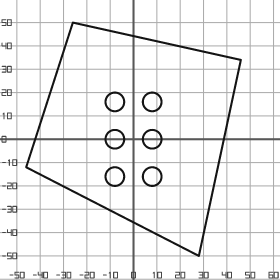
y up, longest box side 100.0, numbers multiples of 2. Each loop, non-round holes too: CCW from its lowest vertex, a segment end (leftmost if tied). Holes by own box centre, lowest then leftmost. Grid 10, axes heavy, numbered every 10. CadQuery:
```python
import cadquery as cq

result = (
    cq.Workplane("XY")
    .moveTo(28.0, -50.0)
    .lineTo(46.0, 34.0)
    .lineTo(-26.0, 50.0)
    .lineTo(-46.0, -12.0)
    .close()
    .moveTo(-8.0, -16.0)
    .circle(4.0)
    .moveTo(8.0, -16.0)
    .circle(4.0)
    .moveTo(-8.0, 0.0)
    .circle(4.0)
    .moveTo(8.0, 0.0)
    .circle(4.0)
    .moveTo(-8.0, 16.0)
    .circle(4.0)
    .moveTo(8.0, 16.0)
    .circle(4.0)
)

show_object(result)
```